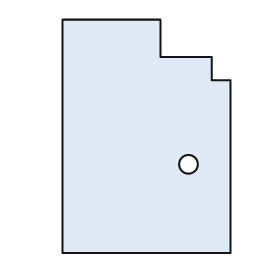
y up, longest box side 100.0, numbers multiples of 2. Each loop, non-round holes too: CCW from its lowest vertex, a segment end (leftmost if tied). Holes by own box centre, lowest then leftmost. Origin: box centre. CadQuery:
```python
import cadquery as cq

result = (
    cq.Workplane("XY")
    .moveTo(-36.0, -50.0)
    .lineTo(36.0, -50.0)
    .lineTo(36.0, 24.0)
    .lineTo(28.0, 24.0)
    .lineTo(28.0, 34.0)
    .lineTo(6.0, 34.0)
    .lineTo(6.0, 50.0)
    .lineTo(-36.0, 50.0)
    .close()
    .moveTo(18.0, -12.0)
    .circle(4.0)
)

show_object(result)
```